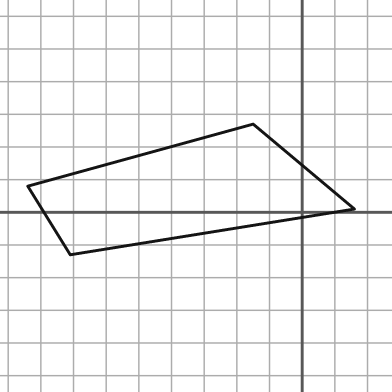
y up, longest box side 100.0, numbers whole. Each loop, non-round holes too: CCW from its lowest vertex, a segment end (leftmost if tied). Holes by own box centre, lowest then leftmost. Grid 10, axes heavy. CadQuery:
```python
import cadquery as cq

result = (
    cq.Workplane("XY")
    .moveTo(-71.0, -13.0)
    .lineTo(16.0, 1.0)
    .lineTo(-15.0, 27.0)
    .lineTo(-84.0, 8.0)
    .close()
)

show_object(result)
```